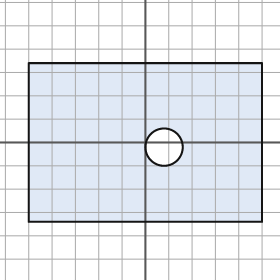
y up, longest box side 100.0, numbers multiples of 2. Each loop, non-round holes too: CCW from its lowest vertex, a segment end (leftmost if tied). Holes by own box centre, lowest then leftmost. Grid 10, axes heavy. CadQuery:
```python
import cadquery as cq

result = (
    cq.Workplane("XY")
    .moveTo(-50.0, -34.0)
    .lineTo(50.0, -34.0)
    .lineTo(50.0, 34.0)
    .lineTo(-50.0, 34.0)
    .close()
    .moveTo(8.0, -2.0)
    .circle(8.0)
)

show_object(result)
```